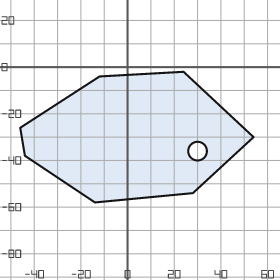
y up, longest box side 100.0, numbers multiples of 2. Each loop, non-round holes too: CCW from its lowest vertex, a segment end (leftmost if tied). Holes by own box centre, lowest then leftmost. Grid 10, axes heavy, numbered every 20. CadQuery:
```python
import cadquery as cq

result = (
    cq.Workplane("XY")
    .moveTo(-14.0, -58.0)
    .lineTo(28.0, -54.0)
    .lineTo(54.0, -30.0)
    .lineTo(24.0, -2.0)
    .lineTo(-12.0, -4.0)
    .lineTo(-46.0, -26.0)
    .lineTo(-44.0, -38.0)
    .close()
    .moveTo(30.0, -36.0)
    .circle(4.0)
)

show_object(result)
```